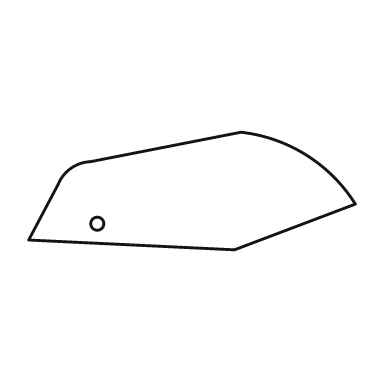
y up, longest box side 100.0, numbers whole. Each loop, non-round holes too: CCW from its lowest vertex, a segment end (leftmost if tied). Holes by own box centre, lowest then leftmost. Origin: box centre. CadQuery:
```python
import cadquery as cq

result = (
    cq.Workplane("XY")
    .moveTo(13.0, -18.0)
    .lineTo(50.0, -4.0)
    .threePointArc((35.0, 11.0), (15.0, 18.0))
    .lineTo(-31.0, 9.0)
    .threePointArc((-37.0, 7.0), (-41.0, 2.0))
    .lineTo(-50.0, -15.0)
    .close()
    .moveTo(-29.0, -10.0)
    .circle(2.0)
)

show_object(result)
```